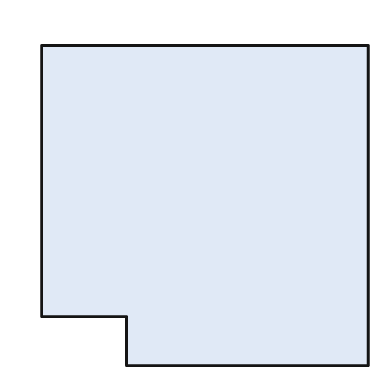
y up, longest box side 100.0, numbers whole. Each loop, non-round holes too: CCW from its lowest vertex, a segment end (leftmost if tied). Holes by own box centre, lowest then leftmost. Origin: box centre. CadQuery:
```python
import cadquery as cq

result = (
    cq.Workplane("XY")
    .moveTo(-24.0, -49.0)
    .lineTo(50.0, -49.0)
    .lineTo(50.0, 49.0)
    .lineTo(-50.0, 49.0)
    .lineTo(-50.0, -34.0)
    .lineTo(-24.0, -34.0)
    .close()
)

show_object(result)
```